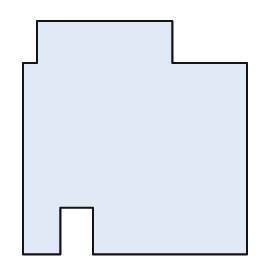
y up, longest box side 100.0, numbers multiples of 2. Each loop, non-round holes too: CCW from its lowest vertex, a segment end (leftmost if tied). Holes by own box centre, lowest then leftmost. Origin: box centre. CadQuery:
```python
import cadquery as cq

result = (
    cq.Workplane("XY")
    .moveTo(-48.0, -50.0)
    .lineTo(-32.0, -50.0)
    .lineTo(-32.0, -30.0)
    .lineTo(-18.0, -30.0)
    .lineTo(-18.0, -50.0)
    .lineTo(48.0, -50.0)
    .lineTo(48.0, 32.0)
    .lineTo(16.0, 32.0)
    .lineTo(16.0, 50.0)
    .lineTo(-42.0, 50.0)
    .lineTo(-42.0, 32.0)
    .lineTo(-48.0, 32.0)
    .close()
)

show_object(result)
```